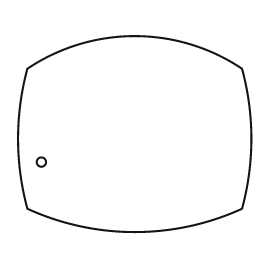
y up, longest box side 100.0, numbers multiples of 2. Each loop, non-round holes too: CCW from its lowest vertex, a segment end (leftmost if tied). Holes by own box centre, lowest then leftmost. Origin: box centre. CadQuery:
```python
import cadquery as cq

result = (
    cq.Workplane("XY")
    .moveTo(-46.0, -32.0)
    .threePointArc((0.0, -42.0), (46.0, -32.0))
    .threePointArc((50.0, -2.0), (46.0, 28.0))
    .threePointArc((0.0, 42.0), (-46.0, 28.0))
    .threePointArc((-50.0, -2.0), (-46.0, -32.0))
    .close()
    .moveTo(-40.0, -12.0)
    .circle(2.0)
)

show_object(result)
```